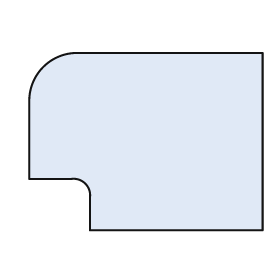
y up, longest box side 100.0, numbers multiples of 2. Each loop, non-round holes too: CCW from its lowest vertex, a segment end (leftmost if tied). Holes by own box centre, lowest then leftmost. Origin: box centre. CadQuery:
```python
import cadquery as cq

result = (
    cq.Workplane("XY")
    .moveTo(-24.0, -38.0)
    .lineTo(50.0, -38.0)
    .lineTo(50.0, 38.0)
    .lineTo(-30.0, 38.0)
    .threePointArc((-44.0, 32.0), (-50.0, 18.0))
    .lineTo(-50.0, -16.0)
    .lineTo(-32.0, -16.0)
    .threePointArc((-26.0, -18.0), (-24.0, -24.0))
    .close()
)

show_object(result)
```